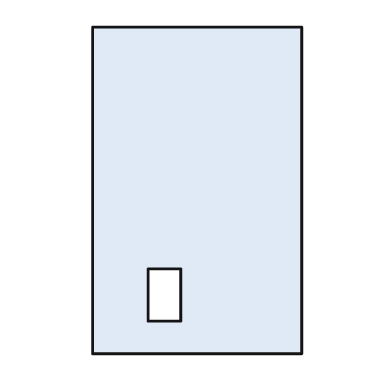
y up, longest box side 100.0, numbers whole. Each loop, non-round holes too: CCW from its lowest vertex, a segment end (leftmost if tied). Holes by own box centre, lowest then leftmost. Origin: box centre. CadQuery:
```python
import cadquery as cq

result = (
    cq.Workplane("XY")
    .moveTo(-32.0, -50.0)
    .lineTo(32.0, -50.0)
    .lineTo(32.0, 50.0)
    .lineTo(-32.0, 50.0)
    .close()
    .moveTo(-15.0, -40.0)
    .lineTo(-5.0, -40.0)
    .lineTo(-5.0, -24.0)
    .lineTo(-15.0, -24.0)
    .close()
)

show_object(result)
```